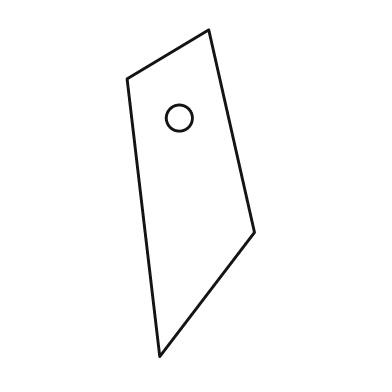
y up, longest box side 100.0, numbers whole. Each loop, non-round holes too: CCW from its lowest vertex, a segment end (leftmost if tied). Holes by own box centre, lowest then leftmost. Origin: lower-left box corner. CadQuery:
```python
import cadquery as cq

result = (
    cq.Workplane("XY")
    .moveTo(10.0, 0.0)
    .lineTo(39.0, 38.0)
    .lineTo(25.0, 100.0)
    .lineTo(0.0, 85.0)
    .close()
    .moveTo(16.0, 73.0)
    .circle(4.0)
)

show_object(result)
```